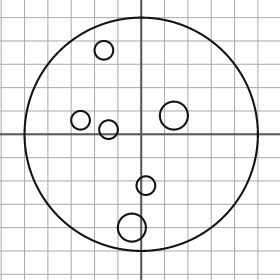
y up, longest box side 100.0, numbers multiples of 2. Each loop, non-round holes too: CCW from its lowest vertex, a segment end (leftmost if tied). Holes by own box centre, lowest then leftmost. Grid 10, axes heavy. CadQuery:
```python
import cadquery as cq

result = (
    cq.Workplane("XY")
    .moveTo(0.0, 0.0)
    .circle(50.0)
    .moveTo(-4.0, -40.0)
    .circle(6.0)
    .moveTo(2.0, -22.0)
    .circle(4.0)
    .moveTo(-14.0, 2.0)
    .circle(4.0)
    .moveTo(-26.0, 6.0)
    .circle(4.0)
    .moveTo(14.0, 8.0)
    .circle(6.0)
    .moveTo(-16.0, 36.0)
    .circle(4.0)
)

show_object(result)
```